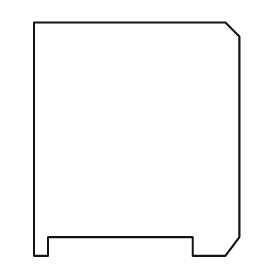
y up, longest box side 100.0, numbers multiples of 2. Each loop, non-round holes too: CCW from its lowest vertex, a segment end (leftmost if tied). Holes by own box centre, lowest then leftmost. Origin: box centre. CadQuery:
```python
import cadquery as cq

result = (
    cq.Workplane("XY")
    .moveTo(-44.0, -50.0)
    .lineTo(-38.0, -50.0)
    .lineTo(-38.0, -42.0)
    .lineTo(24.0, -42.0)
    .lineTo(24.0, -50.0)
    .lineTo(38.0, -50.0)
    .lineTo(44.0, -42.0)
    .lineTo(44.0, 44.0)
    .lineTo(38.0, 50.0)
    .lineTo(-44.0, 50.0)
    .close()
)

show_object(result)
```